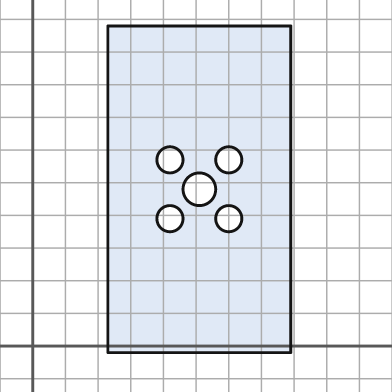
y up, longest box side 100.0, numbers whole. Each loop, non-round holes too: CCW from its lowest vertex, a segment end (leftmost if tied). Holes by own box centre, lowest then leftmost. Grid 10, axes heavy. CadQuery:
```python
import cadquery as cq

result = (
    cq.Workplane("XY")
    .moveTo(23.0, -2.0)
    .lineTo(79.0, -2.0)
    .lineTo(79.0, 98.0)
    .lineTo(23.0, 98.0)
    .close()
    .moveTo(42.0, 39.0)
    .circle(4.0)
    .moveTo(60.0, 39.0)
    .circle(4.0)
    .moveTo(51.0, 48.0)
    .circle(5.0)
    .moveTo(42.0, 57.0)
    .circle(4.0)
    .moveTo(60.0, 57.0)
    .circle(4.0)
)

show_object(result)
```